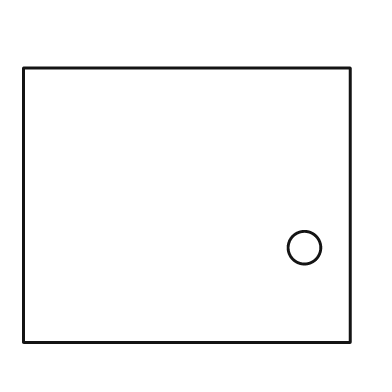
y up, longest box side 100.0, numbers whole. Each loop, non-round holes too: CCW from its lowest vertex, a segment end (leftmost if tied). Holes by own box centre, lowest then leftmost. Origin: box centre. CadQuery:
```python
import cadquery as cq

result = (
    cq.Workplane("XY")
    .moveTo(-50.0, -42.0)
    .lineTo(50.0, -42.0)
    .lineTo(50.0, 42.0)
    .lineTo(-50.0, 42.0)
    .close()
    .moveTo(36.0, -13.0)
    .circle(5.0)
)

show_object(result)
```